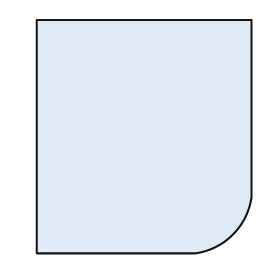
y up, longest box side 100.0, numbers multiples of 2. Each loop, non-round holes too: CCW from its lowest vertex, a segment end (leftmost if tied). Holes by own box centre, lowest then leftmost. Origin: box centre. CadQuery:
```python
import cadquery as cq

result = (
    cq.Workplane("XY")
    .moveTo(-46.0, -50.0)
    .lineTo(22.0, -50.0)
    .threePointArc((38.0, -42.0), (46.0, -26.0))
    .lineTo(46.0, 50.0)
    .lineTo(-46.0, 50.0)
    .close()
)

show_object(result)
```